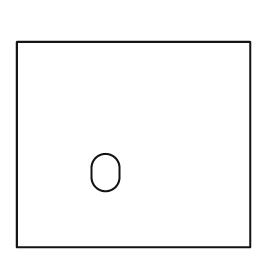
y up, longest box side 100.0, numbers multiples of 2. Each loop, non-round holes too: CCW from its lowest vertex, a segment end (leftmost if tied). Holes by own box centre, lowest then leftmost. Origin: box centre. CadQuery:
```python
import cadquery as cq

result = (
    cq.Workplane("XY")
    .moveTo(-50.0, -44.0)
    .lineTo(50.0, -44.0)
    .lineTo(50.0, 44.0)
    .lineTo(-50.0, 44.0)
    .close()
    .moveTo(-18.0, -14.0)
    .threePointArc((-12.0, -20.0), (-6.0, -14.0))
    .lineTo(-6.0, -10.0)
    .threePointArc((-12.0, -4.0), (-18.0, -10.0))
    .close()
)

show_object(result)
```